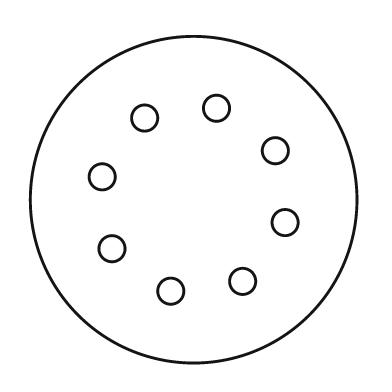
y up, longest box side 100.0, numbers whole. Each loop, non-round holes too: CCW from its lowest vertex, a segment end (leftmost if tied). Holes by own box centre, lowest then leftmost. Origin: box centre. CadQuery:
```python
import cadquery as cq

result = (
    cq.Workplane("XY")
    .moveTo(0.0, 0.0)
    .circle(50.0)
    .moveTo(-7.0, -28.0)
    .circle(4.0)
    .moveTo(15.0, -25.0)
    .circle(4.0)
    .moveTo(-25.0, -15.0)
    .circle(4.0)
    .moveTo(28.0, -7.0)
    .circle(4.0)
    .moveTo(-28.0, 7.0)
    .circle(4.0)
    .moveTo(25.0, 15.0)
    .circle(4.0)
    .moveTo(-15.0, 25.0)
    .circle(4.0)
    .moveTo(7.0, 28.0)
    .circle(4.0)
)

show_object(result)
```